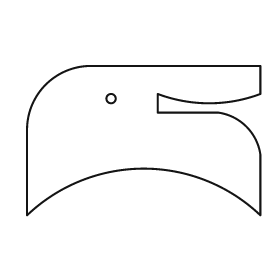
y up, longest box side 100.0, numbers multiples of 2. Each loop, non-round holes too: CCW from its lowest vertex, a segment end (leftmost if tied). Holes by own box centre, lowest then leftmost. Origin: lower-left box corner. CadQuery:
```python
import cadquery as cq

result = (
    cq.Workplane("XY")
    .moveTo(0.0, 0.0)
    .threePointArc((50.0, 20.0), (100.0, 0.0))
    .lineTo(100.0, 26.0)
    .threePointArc((94.0, 38.0), (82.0, 44.0))
    .lineTo(56.0, 44.0)
    .lineTo(56.0, 52.0)
    .threePointArc((78.0, 48.0), (100.0, 52.0))
    .lineTo(100.0, 64.0)
    .lineTo(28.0, 64.0)
    .threePointArc((8.0, 56.0), (0.0, 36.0))
    .close()
    .moveTo(36.0, 50.0)
    .circle(2.0)
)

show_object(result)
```